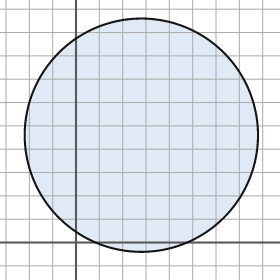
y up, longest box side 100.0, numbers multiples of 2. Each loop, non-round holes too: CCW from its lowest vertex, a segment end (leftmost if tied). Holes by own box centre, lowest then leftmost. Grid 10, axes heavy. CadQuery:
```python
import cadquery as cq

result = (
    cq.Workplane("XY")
    .moveTo(28.0, 46.0)
    .circle(50.0)
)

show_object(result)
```